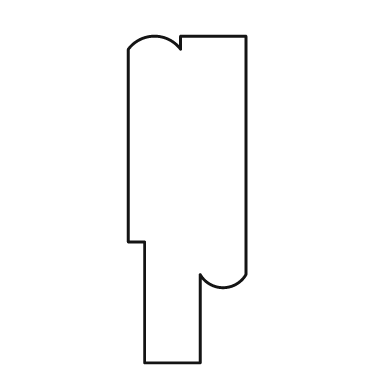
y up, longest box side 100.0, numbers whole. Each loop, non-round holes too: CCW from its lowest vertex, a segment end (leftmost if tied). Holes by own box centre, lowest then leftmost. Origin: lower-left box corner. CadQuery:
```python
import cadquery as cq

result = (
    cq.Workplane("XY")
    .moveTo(5.0, 0.0)
    .lineTo(22.0, 0.0)
    .lineTo(22.0, 27.0)
    .threePointArc((29.0, 23.0), (36.0, 27.0))
    .lineTo(36.0, 100.0)
    .lineTo(16.0, 100.0)
    .lineTo(16.0, 96.0)
    .threePointArc((8.0, 100.0), (0.0, 96.0))
    .lineTo(0.0, 37.0)
    .lineTo(5.0, 37.0)
    .close()
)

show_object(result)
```